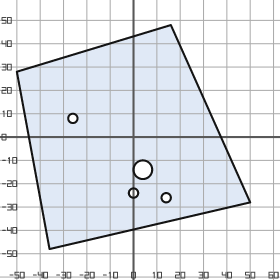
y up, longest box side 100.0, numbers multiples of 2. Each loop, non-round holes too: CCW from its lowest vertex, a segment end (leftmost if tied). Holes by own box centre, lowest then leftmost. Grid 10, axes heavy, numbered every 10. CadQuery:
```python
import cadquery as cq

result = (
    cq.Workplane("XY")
    .moveTo(-36.0, -48.0)
    .lineTo(50.0, -28.0)
    .lineTo(16.0, 48.0)
    .lineTo(-50.0, 28.0)
    .close()
    .moveTo(14.0, -26.0)
    .circle(2.0)
    .moveTo(0.0, -24.0)
    .circle(2.0)
    .moveTo(4.0, -14.0)
    .circle(4.0)
    .moveTo(-26.0, 8.0)
    .circle(2.0)
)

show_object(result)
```